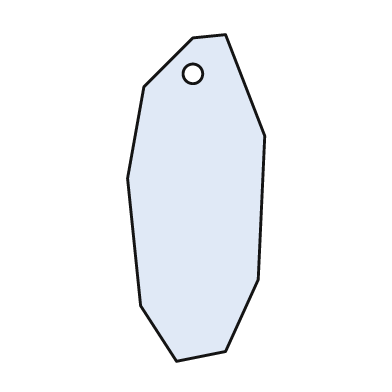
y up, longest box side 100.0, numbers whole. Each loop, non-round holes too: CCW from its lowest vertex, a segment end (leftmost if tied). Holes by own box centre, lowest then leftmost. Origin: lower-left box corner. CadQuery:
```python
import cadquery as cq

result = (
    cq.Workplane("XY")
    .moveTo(15.0, 0.0)
    .lineTo(30.0, 3.0)
    .lineTo(40.0, 25.0)
    .lineTo(42.0, 69.0)
    .lineTo(30.0, 100.0)
    .lineTo(20.0, 99.0)
    .lineTo(5.0, 84.0)
    .lineTo(0.0, 56.0)
    .lineTo(4.0, 17.0)
    .close()
    .moveTo(20.0, 88.0)
    .circle(3.0)
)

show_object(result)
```